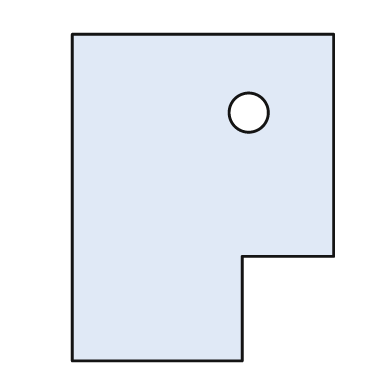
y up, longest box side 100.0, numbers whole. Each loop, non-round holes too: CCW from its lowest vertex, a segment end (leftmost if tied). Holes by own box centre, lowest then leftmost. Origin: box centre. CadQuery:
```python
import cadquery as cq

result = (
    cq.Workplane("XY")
    .moveTo(-40.0, -50.0)
    .lineTo(12.0, -50.0)
    .lineTo(12.0, -18.0)
    .lineTo(40.0, -18.0)
    .lineTo(40.0, 50.0)
    .lineTo(-40.0, 50.0)
    .close()
    .moveTo(14.0, 26.0)
    .circle(6.0)
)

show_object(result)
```